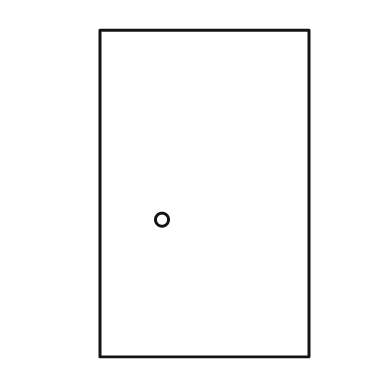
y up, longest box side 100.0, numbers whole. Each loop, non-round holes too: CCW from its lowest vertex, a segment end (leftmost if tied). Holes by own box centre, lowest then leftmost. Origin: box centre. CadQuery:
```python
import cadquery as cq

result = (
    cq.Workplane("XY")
    .moveTo(-32.0, -50.0)
    .lineTo(32.0, -50.0)
    .lineTo(32.0, 50.0)
    .lineTo(-32.0, 50.0)
    .close()
    .moveTo(-13.0, -8.0)
    .circle(2.0)
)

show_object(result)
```